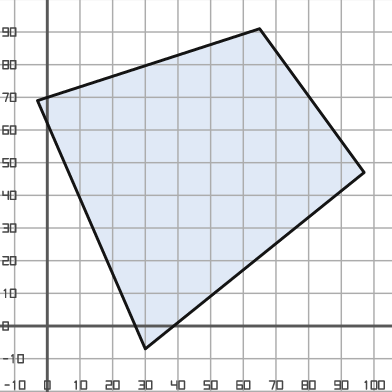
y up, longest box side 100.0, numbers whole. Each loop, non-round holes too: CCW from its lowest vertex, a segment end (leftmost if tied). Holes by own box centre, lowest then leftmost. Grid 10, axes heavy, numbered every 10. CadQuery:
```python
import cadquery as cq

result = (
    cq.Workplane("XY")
    .moveTo(30.0, -7.0)
    .lineTo(97.0, 47.0)
    .lineTo(65.0, 91.0)
    .lineTo(-3.0, 69.0)
    .close()
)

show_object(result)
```